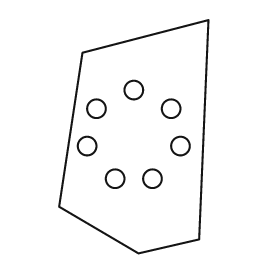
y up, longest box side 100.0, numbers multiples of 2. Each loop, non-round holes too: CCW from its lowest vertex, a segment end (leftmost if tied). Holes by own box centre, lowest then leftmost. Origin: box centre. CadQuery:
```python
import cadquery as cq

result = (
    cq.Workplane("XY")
    .moveTo(2.0, -50.0)
    .lineTo(28.0, -44.0)
    .lineTo(32.0, 50.0)
    .lineTo(-22.0, 36.0)
    .lineTo(-32.0, -30.0)
    .close()
    .moveTo(-8.0, -18.0)
    .circle(4.0)
    .moveTo(8.0, -18.0)
    .circle(4.0)
    .moveTo(-20.0, -4.0)
    .circle(4.0)
    .moveTo(20.0, -4.0)
    .circle(4.0)
    .moveTo(-16.0, 12.0)
    .circle(4.0)
    .moveTo(16.0, 12.0)
    .circle(4.0)
    .moveTo(0.0, 20.0)
    .circle(4.0)
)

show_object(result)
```